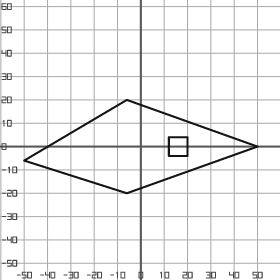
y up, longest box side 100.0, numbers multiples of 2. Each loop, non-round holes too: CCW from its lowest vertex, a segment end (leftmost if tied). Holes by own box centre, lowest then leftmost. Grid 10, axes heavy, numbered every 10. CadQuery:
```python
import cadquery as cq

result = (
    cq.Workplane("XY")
    .moveTo(-6.0, -20.0)
    .lineTo(50.0, 0.0)
    .lineTo(-6.0, 20.0)
    .lineTo(-50.0, -6.0)
    .close()
    .moveTo(12.0, -4.0)
    .lineTo(20.0, -4.0)
    .lineTo(20.0, 4.0)
    .lineTo(12.0, 4.0)
    .close()
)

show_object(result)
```